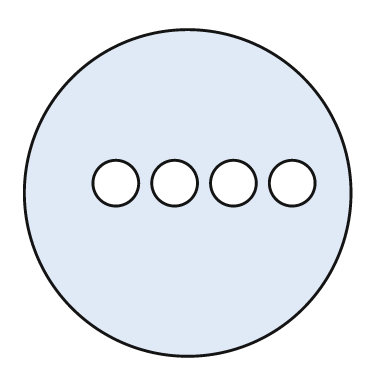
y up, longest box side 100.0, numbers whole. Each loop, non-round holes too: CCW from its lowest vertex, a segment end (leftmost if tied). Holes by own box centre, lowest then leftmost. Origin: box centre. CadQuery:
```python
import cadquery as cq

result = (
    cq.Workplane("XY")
    .moveTo(0.0, 0.0)
    .circle(50.0)
    .moveTo(-22.0, 3.0)
    .circle(7.0)
    .moveTo(-4.0, 3.0)
    .circle(7.0)
    .moveTo(14.0, 3.0)
    .circle(7.0)
    .moveTo(32.0, 3.0)
    .circle(7.0)
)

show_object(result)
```